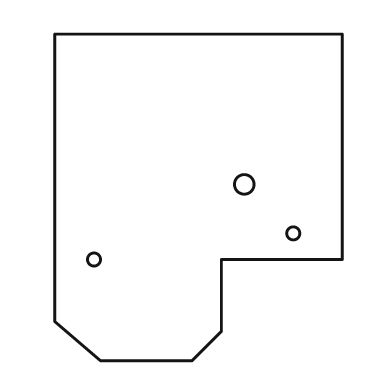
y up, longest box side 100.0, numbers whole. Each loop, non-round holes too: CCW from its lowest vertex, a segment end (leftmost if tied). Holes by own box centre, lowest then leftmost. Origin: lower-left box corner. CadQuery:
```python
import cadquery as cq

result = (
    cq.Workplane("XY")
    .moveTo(14.0, 0.0)
    .lineTo(42.0, 0.0)
    .lineTo(51.0, 9.0)
    .lineTo(51.0, 31.0)
    .lineTo(88.0, 31.0)
    .lineTo(88.0, 100.0)
    .lineTo(0.0, 100.0)
    .lineTo(0.0, 12.0)
    .close()
    .moveTo(12.0, 31.0)
    .circle(2.0)
    .moveTo(73.0, 39.0)
    .circle(2.0)
    .moveTo(58.0, 54.0)
    .circle(3.0)
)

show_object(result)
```